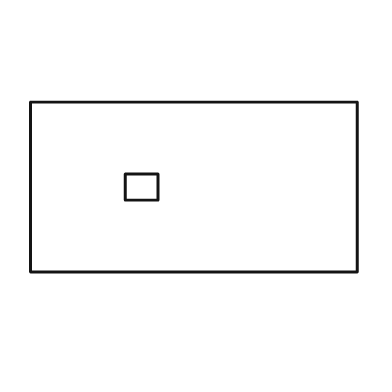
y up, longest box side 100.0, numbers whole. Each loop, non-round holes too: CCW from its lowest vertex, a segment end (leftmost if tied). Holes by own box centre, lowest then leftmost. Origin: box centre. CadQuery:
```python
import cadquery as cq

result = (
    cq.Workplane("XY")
    .moveTo(-50.0, -26.0)
    .lineTo(50.0, -26.0)
    .lineTo(50.0, 26.0)
    .lineTo(-50.0, 26.0)
    .close()
    .moveTo(-21.0, -4.0)
    .lineTo(-11.0, -4.0)
    .lineTo(-11.0, 4.0)
    .lineTo(-21.0, 4.0)
    .close()
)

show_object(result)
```